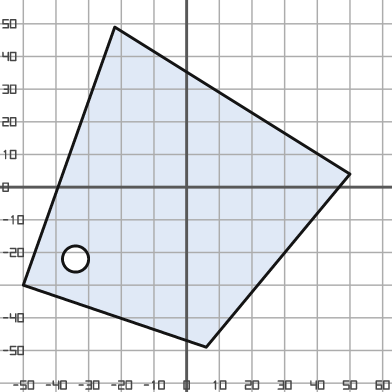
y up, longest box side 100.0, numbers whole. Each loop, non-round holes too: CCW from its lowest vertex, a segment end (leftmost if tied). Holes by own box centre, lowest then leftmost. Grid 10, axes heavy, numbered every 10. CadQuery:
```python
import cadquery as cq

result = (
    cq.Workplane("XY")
    .moveTo(6.0, -49.0)
    .lineTo(50.0, 4.0)
    .lineTo(-22.0, 49.0)
    .lineTo(-50.0, -30.0)
    .close()
    .moveTo(-34.0, -22.0)
    .circle(4.0)
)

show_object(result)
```